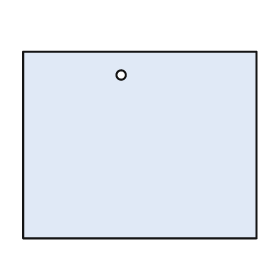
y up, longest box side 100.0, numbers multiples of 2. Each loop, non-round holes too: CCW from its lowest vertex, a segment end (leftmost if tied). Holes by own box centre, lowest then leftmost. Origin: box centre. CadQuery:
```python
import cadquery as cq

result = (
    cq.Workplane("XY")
    .moveTo(-50.0, -40.0)
    .lineTo(50.0, -40.0)
    .lineTo(50.0, 40.0)
    .lineTo(-50.0, 40.0)
    .close()
    .moveTo(-8.0, 30.0)
    .circle(2.0)
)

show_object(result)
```